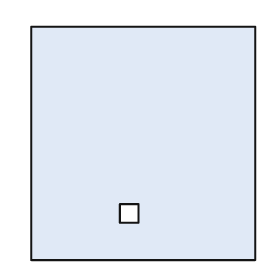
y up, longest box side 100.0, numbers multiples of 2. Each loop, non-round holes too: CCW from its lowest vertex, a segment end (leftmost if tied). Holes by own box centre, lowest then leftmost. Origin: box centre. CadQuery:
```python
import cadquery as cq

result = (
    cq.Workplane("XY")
    .moveTo(-48.0, -50.0)
    .lineTo(48.0, -50.0)
    .lineTo(48.0, 50.0)
    .lineTo(-48.0, 50.0)
    .close()
    .moveTo(-10.0, -34.0)
    .lineTo(-2.0, -34.0)
    .lineTo(-2.0, -26.0)
    .lineTo(-10.0, -26.0)
    .close()
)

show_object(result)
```